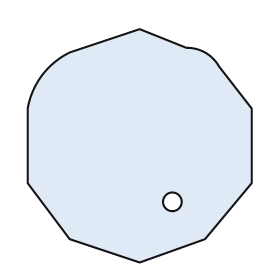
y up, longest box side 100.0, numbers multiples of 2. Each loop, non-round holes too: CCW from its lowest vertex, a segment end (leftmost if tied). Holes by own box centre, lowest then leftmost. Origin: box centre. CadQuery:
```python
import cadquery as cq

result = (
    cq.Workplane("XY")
    .moveTo(0.0, -50.0)
    .lineTo(28.0, -40.0)
    .lineTo(48.0, -16.0)
    .lineTo(48.0, 16.0)
    .lineTo(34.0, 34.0)
    .threePointArc((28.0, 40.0), (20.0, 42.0))
    .lineTo(0.0, 50.0)
    .lineTo(-30.0, 40.0)
    .threePointArc((-42.0, 30.0), (-48.0, 16.0))
    .lineTo(-48.0, -16.0)
    .lineTo(-30.0, -40.0)
    .close()
    .moveTo(14.0, -24.0)
    .circle(4.0)
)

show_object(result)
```